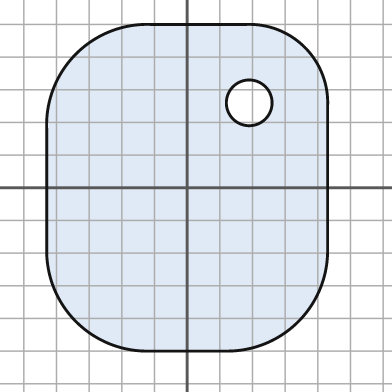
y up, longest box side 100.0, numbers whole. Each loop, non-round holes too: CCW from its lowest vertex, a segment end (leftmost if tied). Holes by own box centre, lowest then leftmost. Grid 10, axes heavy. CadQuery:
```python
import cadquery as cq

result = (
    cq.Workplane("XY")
    .moveTo(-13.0, -50.0)
    .lineTo(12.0, -50.0)
    .threePointArc((34.0, -41.0), (43.0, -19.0))
    .lineTo(43.0, 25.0)
    .threePointArc((36.0, 43.0), (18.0, 50.0))
    .lineTo(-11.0, 50.0)
    .threePointArc((-34.0, 41.0), (-43.0, 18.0))
    .lineTo(-43.0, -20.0)
    .threePointArc((-34.0, -41.0), (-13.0, -50.0))
    .close()
    .moveTo(19.0, 26.0)
    .circle(7.0)
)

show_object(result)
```